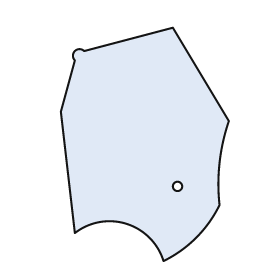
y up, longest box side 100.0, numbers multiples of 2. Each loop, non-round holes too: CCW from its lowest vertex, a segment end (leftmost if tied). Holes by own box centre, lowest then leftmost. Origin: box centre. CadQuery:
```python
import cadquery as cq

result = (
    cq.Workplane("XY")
    .moveTo(8.0, -50.0)
    .threePointArc((22.0, -40.0), (32.0, -26.0))
    .threePointArc((32.0, -8.0), (36.0, 10.0))
    .lineTo(12.0, 50.0)
    .lineTo(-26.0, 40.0)
    .threePointArc((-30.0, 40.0), (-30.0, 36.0))
    .lineTo(-36.0, 14.0)
    .lineTo(-30.0, -38.0)
    .threePointArc((-8.0, -34.0), (8.0, -50.0))
    .close()
    .moveTo(14.0, -18.0)
    .circle(2.0)
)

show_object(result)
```